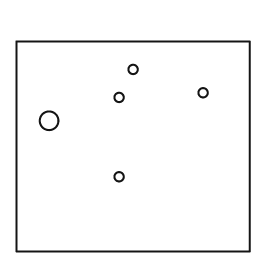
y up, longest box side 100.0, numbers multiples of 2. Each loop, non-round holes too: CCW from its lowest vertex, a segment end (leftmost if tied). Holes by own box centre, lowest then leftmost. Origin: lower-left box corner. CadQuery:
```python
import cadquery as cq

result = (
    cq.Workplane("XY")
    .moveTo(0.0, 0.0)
    .lineTo(100.0, 0.0)
    .lineTo(100.0, 90.0)
    .lineTo(0.0, 90.0)
    .close()
    .moveTo(44.0, 32.0)
    .circle(2.0)
    .moveTo(14.0, 56.0)
    .circle(4.0)
    .moveTo(44.0, 66.0)
    .circle(2.0)
    .moveTo(80.0, 68.0)
    .circle(2.0)
    .moveTo(50.0, 78.0)
    .circle(2.0)
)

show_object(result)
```